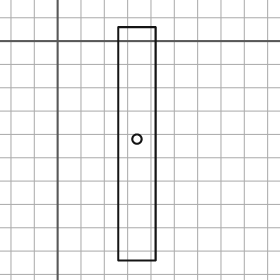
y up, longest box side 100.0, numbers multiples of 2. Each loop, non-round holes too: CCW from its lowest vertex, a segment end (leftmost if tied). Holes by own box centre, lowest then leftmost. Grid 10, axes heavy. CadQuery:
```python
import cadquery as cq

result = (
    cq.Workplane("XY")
    .moveTo(26.0, -94.0)
    .lineTo(42.0, -94.0)
    .lineTo(42.0, 6.0)
    .lineTo(26.0, 6.0)
    .close()
    .moveTo(34.0, -42.0)
    .circle(2.0)
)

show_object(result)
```